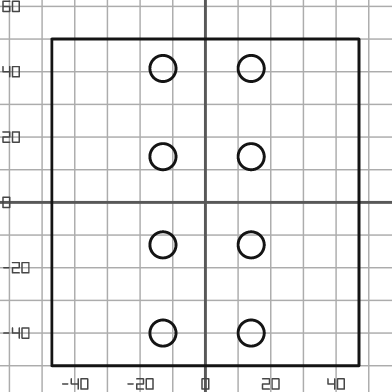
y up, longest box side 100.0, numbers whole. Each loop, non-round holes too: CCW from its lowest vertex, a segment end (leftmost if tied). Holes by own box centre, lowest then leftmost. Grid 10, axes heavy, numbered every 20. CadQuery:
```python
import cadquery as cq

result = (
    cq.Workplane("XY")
    .moveTo(-47.0, -50.0)
    .lineTo(47.0, -50.0)
    .lineTo(47.0, 50.0)
    .lineTo(-47.0, 50.0)
    .close()
    .moveTo(-13.0, -40.0)
    .circle(4.0)
    .moveTo(14.0, -40.0)
    .circle(4.0)
    .moveTo(-13.0, -13.0)
    .circle(4.0)
    .moveTo(14.0, -13.0)
    .circle(4.0)
    .moveTo(-13.0, 14.0)
    .circle(4.0)
    .moveTo(14.0, 14.0)
    .circle(4.0)
    .moveTo(-13.0, 41.0)
    .circle(4.0)
    .moveTo(14.0, 41.0)
    .circle(4.0)
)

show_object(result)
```